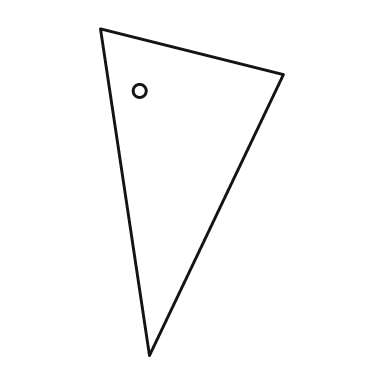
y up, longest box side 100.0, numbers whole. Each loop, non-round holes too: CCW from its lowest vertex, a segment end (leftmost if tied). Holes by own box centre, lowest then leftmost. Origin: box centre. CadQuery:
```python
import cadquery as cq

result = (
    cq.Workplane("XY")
    .moveTo(-13.0, -50.0)
    .lineTo(28.0, 36.0)
    .lineTo(-28.0, 50.0)
    .close()
    .moveTo(-16.0, 31.0)
    .circle(2.0)
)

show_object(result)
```